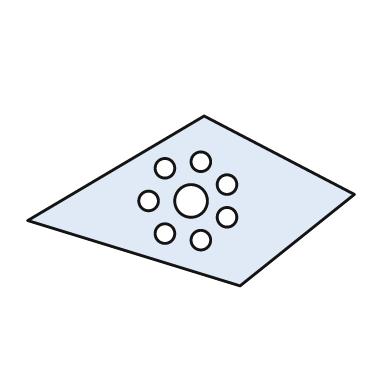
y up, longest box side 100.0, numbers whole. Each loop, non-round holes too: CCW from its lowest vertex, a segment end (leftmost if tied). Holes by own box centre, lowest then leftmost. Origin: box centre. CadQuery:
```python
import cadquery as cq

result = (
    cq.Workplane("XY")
    .moveTo(15.0, -26.0)
    .lineTo(50.0, 2.0)
    .lineTo(4.0, 26.0)
    .lineTo(-50.0, -6.0)
    .close()
    .moveTo(3.0, -12.0)
    .circle(3.0)
    .moveTo(-8.0, -10.0)
    .circle(3.0)
    .moveTo(11.0, -5.0)
    .circle(3.0)
    .moveTo(-13.0, 0.0)
    .circle(3.0)
    .moveTo(0.0, 0.0)
    .circle(5.0)
    .moveTo(11.0, 5.0)
    .circle(3.0)
    .moveTo(-8.0, 10.0)
    .circle(3.0)
    .moveTo(3.0, 12.0)
    .circle(3.0)
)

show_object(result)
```